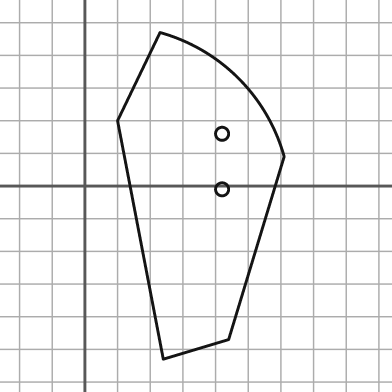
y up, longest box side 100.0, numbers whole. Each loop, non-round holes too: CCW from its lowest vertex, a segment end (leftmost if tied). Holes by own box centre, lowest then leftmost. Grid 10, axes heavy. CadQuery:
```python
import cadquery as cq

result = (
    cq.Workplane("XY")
    .moveTo(24.0, -53.0)
    .lineTo(44.0, -47.0)
    .lineTo(61.0, 9.0)
    .threePointArc((47.0, 33.0), (23.0, 47.0))
    .lineTo(10.0, 20.0)
    .close()
    .moveTo(42.0, -1.0)
    .circle(2.0)
    .moveTo(42.0, 16.0)
    .circle(2.0)
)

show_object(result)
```